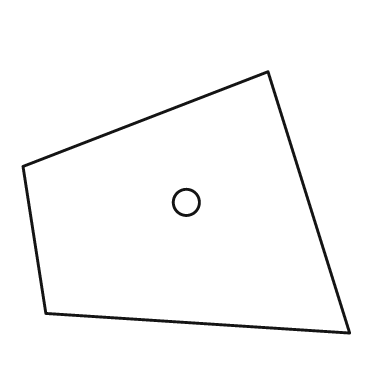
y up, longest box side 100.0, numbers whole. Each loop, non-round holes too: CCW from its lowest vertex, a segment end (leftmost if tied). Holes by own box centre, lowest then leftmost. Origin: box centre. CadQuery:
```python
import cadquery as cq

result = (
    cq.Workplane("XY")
    .moveTo(50.0, -40.0)
    .lineTo(25.0, 40.0)
    .lineTo(-50.0, 11.0)
    .lineTo(-43.0, -34.0)
    .close()
    .moveTo(0.0, 0.0)
    .circle(4.0)
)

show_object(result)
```